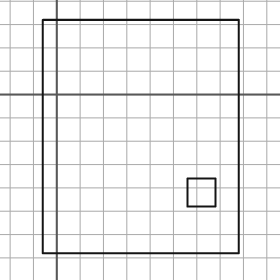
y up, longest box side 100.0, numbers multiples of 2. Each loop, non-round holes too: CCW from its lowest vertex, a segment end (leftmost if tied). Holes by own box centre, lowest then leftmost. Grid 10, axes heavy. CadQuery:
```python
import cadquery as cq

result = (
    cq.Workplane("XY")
    .moveTo(-6.0, -68.0)
    .lineTo(78.0, -68.0)
    .lineTo(78.0, 32.0)
    .lineTo(-6.0, 32.0)
    .close()
    .moveTo(56.0, -48.0)
    .lineTo(68.0, -48.0)
    .lineTo(68.0, -36.0)
    .lineTo(56.0, -36.0)
    .close()
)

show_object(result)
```